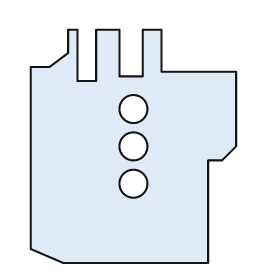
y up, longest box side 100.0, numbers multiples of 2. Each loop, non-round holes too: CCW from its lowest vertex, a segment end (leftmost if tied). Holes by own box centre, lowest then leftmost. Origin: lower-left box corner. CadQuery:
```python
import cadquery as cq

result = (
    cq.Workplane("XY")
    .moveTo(14.0, 0.0)
    .lineTo(76.0, 0.0)
    .lineTo(76.0, 44.0)
    .lineTo(82.0, 44.0)
    .lineTo(88.0, 50.0)
    .lineTo(88.0, 82.0)
    .lineTo(56.0, 82.0)
    .lineTo(56.0, 100.0)
    .lineTo(48.0, 100.0)
    .lineTo(48.0, 80.0)
    .lineTo(38.0, 80.0)
    .lineTo(38.0, 100.0)
    .lineTo(28.0, 100.0)
    .lineTo(28.0, 78.0)
    .lineTo(20.0, 78.0)
    .lineTo(20.0, 100.0)
    .lineTo(16.0, 100.0)
    .lineTo(16.0, 90.0)
    .lineTo(8.0, 84.0)
    .lineTo(0.0, 84.0)
    .lineTo(0.0, 6.0)
    .close()
    .moveTo(44.0, 34.0)
    .circle(6.0)
    .moveTo(44.0, 50.0)
    .circle(6.0)
    .moveTo(44.0, 66.0)
    .circle(6.0)
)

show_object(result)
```